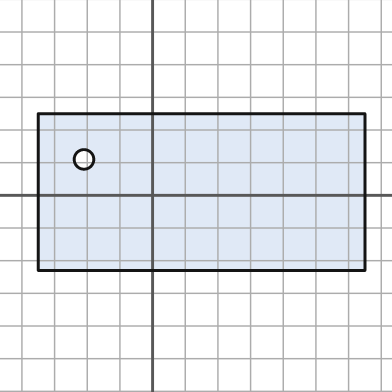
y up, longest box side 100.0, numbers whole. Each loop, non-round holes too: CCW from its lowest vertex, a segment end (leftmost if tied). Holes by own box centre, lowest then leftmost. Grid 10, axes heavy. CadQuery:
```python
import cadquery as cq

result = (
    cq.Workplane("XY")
    .moveTo(-35.0, -23.0)
    .lineTo(65.0, -23.0)
    .lineTo(65.0, 25.0)
    .lineTo(-35.0, 25.0)
    .close()
    .moveTo(-21.0, 11.0)
    .circle(3.0)
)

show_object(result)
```